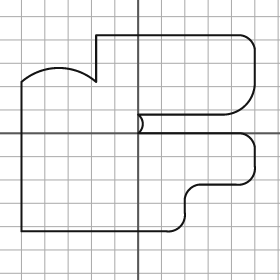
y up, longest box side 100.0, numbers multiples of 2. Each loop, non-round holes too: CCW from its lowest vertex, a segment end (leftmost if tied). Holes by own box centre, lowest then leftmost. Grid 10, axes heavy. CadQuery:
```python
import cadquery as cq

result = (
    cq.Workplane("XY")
    .moveTo(-50.0, -42.0)
    .lineTo(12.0, -42.0)
    .threePointArc((18.0, -40.0), (20.0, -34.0))
    .lineTo(20.0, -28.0)
    .threePointArc((22.0, -24.0), (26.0, -22.0))
    .lineTo(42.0, -22.0)
    .threePointArc((48.0, -20.0), (50.0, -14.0))
    .lineTo(50.0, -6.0)
    .threePointArc((48.0, -2.0), (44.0, 0.0))
    .lineTo(0.0, 0.0)
    .threePointArc((2.0, 4.0), (0.0, 8.0))
    .lineTo(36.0, 8.0)
    .threePointArc((46.0, 12.0), (50.0, 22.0))
    .lineTo(50.0, 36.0)
    .threePointArc((48.0, 40.0), (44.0, 42.0))
    .lineTo(-18.0, 42.0)
    .lineTo(-18.0, 22.0)
    .threePointArc((-34.0, 28.0), (-50.0, 22.0))
    .close()
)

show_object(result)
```